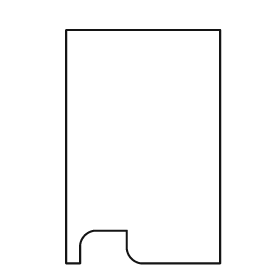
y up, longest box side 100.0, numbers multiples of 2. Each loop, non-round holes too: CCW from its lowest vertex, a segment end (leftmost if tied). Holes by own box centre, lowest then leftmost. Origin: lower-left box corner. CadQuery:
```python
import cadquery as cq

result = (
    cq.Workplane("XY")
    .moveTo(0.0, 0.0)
    .lineTo(6.0, 0.0)
    .lineTo(6.0, 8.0)
    .threePointArc((8.0, 12.0), (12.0, 14.0))
    .lineTo(26.0, 14.0)
    .lineTo(26.0, 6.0)
    .threePointArc((28.0, 2.0), (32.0, 0.0))
    .lineTo(66.0, 0.0)
    .lineTo(66.0, 100.0)
    .lineTo(0.0, 100.0)
    .close()
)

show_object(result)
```